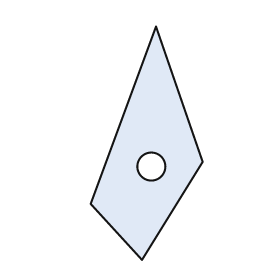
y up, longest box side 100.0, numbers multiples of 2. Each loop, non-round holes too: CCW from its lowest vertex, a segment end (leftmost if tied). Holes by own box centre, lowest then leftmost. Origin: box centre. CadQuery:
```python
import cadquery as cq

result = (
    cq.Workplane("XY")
    .moveTo(-2.0, -50.0)
    .lineTo(24.0, -8.0)
    .lineTo(4.0, 50.0)
    .lineTo(-24.0, -26.0)
    .close()
    .moveTo(2.0, -10.0)
    .circle(6.0)
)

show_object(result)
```